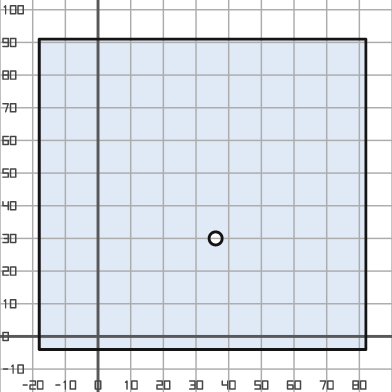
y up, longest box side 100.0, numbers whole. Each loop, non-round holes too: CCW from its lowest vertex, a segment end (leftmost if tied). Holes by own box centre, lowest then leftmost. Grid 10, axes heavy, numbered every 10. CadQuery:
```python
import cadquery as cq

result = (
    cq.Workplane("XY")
    .moveTo(-18.0, -4.0)
    .lineTo(82.0, -4.0)
    .lineTo(82.0, 91.0)
    .lineTo(-18.0, 91.0)
    .close()
    .moveTo(36.0, 30.0)
    .circle(2.0)
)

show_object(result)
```